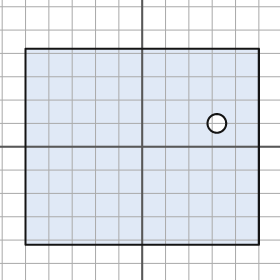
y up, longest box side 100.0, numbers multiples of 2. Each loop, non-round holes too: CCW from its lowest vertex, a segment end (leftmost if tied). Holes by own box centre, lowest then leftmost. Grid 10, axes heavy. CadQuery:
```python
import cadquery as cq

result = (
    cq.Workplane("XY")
    .moveTo(-50.0, -42.0)
    .lineTo(50.0, -42.0)
    .lineTo(50.0, 42.0)
    .lineTo(-50.0, 42.0)
    .close()
    .moveTo(32.0, 10.0)
    .circle(4.0)
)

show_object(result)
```